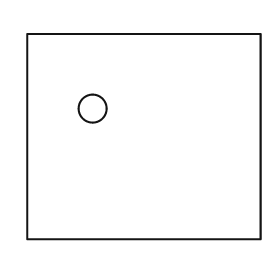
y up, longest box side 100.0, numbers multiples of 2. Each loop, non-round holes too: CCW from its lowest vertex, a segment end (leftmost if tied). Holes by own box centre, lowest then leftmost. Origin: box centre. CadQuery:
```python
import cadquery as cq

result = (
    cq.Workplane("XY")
    .moveTo(-50.0, -44.0)
    .lineTo(50.0, -44.0)
    .lineTo(50.0, 44.0)
    .lineTo(-50.0, 44.0)
    .close()
    .moveTo(-22.0, 12.0)
    .circle(6.0)
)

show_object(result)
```